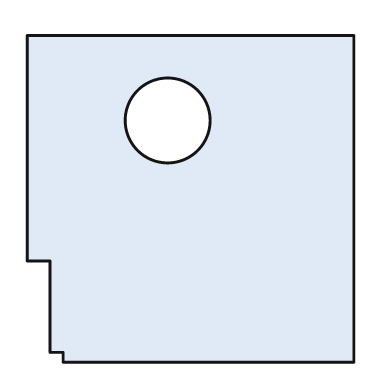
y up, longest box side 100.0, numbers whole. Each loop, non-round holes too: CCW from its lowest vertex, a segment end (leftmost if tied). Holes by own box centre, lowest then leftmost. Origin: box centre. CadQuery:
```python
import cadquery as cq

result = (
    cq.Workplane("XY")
    .moveTo(-39.0, -50.0)
    .lineTo(50.0, -50.0)
    .lineTo(50.0, 50.0)
    .lineTo(-50.0, 50.0)
    .lineTo(-50.0, -19.0)
    .lineTo(-43.0, -19.0)
    .lineTo(-43.0, -47.0)
    .lineTo(-39.0, -47.0)
    .close()
    .moveTo(-7.0, 24.0)
    .circle(13.0)
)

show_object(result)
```